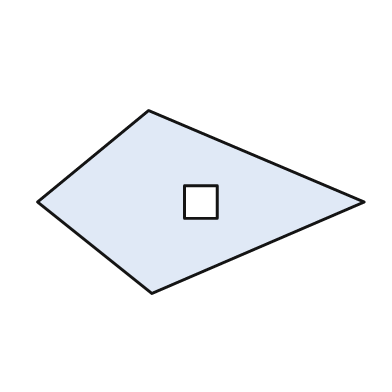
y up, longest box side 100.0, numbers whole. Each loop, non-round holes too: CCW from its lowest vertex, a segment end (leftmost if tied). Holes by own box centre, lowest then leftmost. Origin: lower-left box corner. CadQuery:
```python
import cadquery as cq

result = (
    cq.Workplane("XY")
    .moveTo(35.0, 0.0)
    .lineTo(100.0, 28.0)
    .lineTo(34.0, 56.0)
    .lineTo(0.0, 28.0)
    .close()
    .moveTo(45.0, 23.0)
    .lineTo(55.0, 23.0)
    .lineTo(55.0, 33.0)
    .lineTo(45.0, 33.0)
    .close()
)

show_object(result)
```